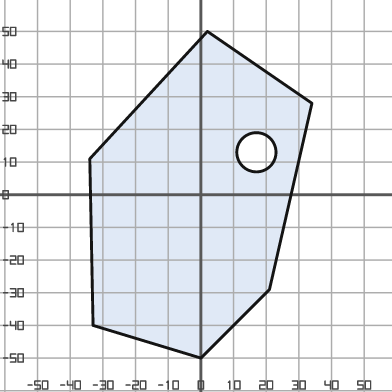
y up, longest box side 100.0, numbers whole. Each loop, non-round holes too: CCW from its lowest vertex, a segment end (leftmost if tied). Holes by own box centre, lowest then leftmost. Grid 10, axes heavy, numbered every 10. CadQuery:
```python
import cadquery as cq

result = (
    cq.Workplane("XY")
    .moveTo(0.0, -50.0)
    .lineTo(21.0, -29.0)
    .lineTo(34.0, 28.0)
    .lineTo(2.0, 50.0)
    .lineTo(-34.0, 11.0)
    .lineTo(-33.0, -40.0)
    .close()
    .moveTo(17.0, 13.0)
    .circle(6.0)
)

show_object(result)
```